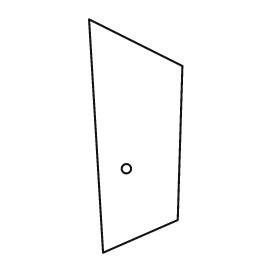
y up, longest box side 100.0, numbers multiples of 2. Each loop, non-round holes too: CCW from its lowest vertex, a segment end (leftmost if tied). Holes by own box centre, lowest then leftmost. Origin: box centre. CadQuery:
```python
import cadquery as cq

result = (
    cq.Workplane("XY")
    .moveTo(-14.0, -50.0)
    .lineTo(18.0, -36.0)
    .lineTo(20.0, 30.0)
    .lineTo(-20.0, 50.0)
    .close()
    .moveTo(-4.0, -14.0)
    .circle(2.0)
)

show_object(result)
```